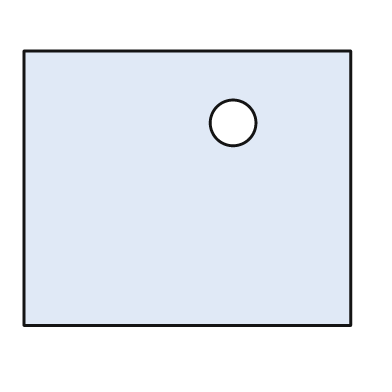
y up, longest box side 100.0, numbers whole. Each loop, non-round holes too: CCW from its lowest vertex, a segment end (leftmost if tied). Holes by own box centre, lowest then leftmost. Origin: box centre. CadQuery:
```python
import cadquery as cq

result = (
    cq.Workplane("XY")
    .moveTo(-50.0, -42.0)
    .lineTo(50.0, -42.0)
    .lineTo(50.0, 42.0)
    .lineTo(-50.0, 42.0)
    .close()
    .moveTo(14.0, 20.0)
    .circle(7.0)
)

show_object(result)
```